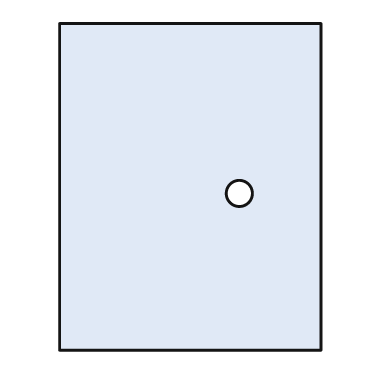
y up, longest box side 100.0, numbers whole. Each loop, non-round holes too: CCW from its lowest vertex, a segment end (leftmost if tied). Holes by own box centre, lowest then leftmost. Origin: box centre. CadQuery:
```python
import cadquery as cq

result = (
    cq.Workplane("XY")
    .moveTo(-40.0, -50.0)
    .lineTo(40.0, -50.0)
    .lineTo(40.0, 50.0)
    .lineTo(-40.0, 50.0)
    .close()
    .moveTo(15.0, -2.0)
    .circle(4.0)
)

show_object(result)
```